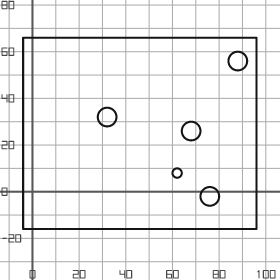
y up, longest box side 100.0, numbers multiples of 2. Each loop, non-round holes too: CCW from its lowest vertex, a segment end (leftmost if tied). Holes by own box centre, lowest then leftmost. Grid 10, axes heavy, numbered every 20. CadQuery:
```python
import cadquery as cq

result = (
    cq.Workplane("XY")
    .moveTo(-4.0, -16.0)
    .lineTo(96.0, -16.0)
    .lineTo(96.0, 66.0)
    .lineTo(-4.0, 66.0)
    .close()
    .moveTo(76.0, -2.0)
    .circle(4.0)
    .moveTo(62.0, 8.0)
    .circle(2.0)
    .moveTo(68.0, 26.0)
    .circle(4.0)
    .moveTo(32.0, 32.0)
    .circle(4.0)
    .moveTo(88.0, 56.0)
    .circle(4.0)
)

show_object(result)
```